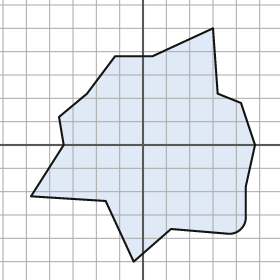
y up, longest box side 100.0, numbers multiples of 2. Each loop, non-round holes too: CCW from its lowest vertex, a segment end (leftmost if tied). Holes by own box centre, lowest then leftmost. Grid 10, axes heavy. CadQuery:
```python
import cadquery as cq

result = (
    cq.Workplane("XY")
    .moveTo(-4.0, -50.0)
    .lineTo(12.0, -36.0)
    .lineTo(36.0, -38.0)
    .threePointArc((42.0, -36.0), (44.0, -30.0))
    .lineTo(44.0, -18.0)
    .lineTo(48.0, 0.0)
    .lineTo(42.0, 18.0)
    .lineTo(32.0, 22.0)
    .lineTo(30.0, 50.0)
    .lineTo(4.0, 38.0)
    .lineTo(-12.0, 38.0)
    .lineTo(-24.0, 22.0)
    .lineTo(-36.0, 12.0)
    .lineTo(-34.0, 0.0)
    .lineTo(-48.0, -22.0)
    .lineTo(-16.0, -24.0)
    .close()
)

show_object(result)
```